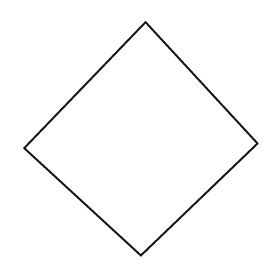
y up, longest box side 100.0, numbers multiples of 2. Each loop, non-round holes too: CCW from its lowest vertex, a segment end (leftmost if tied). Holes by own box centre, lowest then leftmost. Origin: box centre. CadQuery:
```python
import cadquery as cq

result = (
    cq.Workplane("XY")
    .moveTo(0.0, -50.0)
    .lineTo(50.0, -2.0)
    .lineTo(2.0, 50.0)
    .lineTo(-50.0, -4.0)
    .close()
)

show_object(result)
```